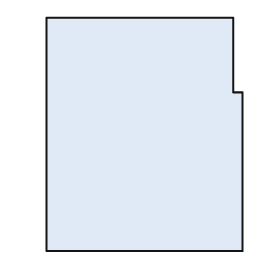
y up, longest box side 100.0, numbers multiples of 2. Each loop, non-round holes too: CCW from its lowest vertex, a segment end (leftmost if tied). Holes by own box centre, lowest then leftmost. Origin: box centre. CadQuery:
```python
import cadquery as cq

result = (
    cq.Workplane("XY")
    .moveTo(-42.0, -50.0)
    .lineTo(42.0, -50.0)
    .lineTo(42.0, 18.0)
    .lineTo(38.0, 18.0)
    .lineTo(38.0, 50.0)
    .lineTo(-42.0, 50.0)
    .close()
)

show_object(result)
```